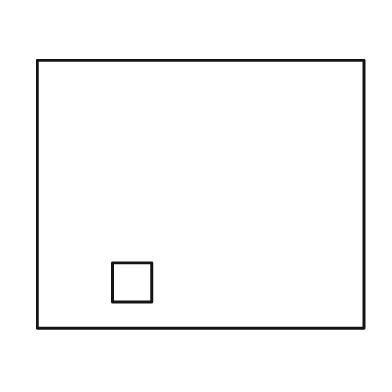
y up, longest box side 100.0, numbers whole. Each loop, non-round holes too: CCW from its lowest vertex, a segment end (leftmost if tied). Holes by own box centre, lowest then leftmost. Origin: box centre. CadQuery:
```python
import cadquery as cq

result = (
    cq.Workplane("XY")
    .moveTo(-50.0, -41.0)
    .lineTo(50.0, -41.0)
    .lineTo(50.0, 41.0)
    .lineTo(-50.0, 41.0)
    .close()
    .moveTo(-27.0, -33.0)
    .lineTo(-15.0, -33.0)
    .lineTo(-15.0, -21.0)
    .lineTo(-27.0, -21.0)
    .close()
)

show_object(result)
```